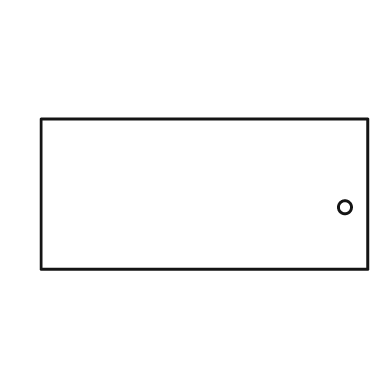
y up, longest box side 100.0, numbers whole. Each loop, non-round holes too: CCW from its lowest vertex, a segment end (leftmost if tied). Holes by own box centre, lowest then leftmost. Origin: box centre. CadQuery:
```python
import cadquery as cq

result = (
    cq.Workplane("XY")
    .moveTo(-50.0, -23.0)
    .lineTo(50.0, -23.0)
    .lineTo(50.0, 23.0)
    .lineTo(-50.0, 23.0)
    .close()
    .moveTo(43.0, -4.0)
    .circle(2.0)
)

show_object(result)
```